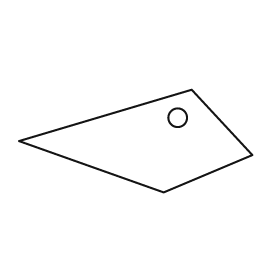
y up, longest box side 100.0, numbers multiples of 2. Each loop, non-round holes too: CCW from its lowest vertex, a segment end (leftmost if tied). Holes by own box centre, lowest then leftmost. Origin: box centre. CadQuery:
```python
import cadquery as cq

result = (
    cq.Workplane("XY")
    .moveTo(12.0, -22.0)
    .lineTo(50.0, -6.0)
    .lineTo(24.0, 22.0)
    .lineTo(-50.0, 0.0)
    .close()
    .moveTo(18.0, 10.0)
    .circle(4.0)
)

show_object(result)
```